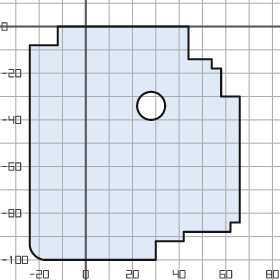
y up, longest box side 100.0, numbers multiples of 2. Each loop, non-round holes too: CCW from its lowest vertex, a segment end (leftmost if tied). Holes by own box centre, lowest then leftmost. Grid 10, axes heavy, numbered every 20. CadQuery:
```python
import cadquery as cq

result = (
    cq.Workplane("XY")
    .moveTo(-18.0, -100.0)
    .lineTo(30.0, -100.0)
    .lineTo(30.0, -92.0)
    .lineTo(42.0, -92.0)
    .lineTo(42.0, -88.0)
    .lineTo(62.0, -88.0)
    .lineTo(62.0, -84.0)
    .lineTo(66.0, -84.0)
    .lineTo(66.0, -30.0)
    .lineTo(58.0, -30.0)
    .lineTo(58.0, -18.0)
    .lineTo(54.0, -18.0)
    .lineTo(54.0, -14.0)
    .lineTo(44.0, -14.0)
    .lineTo(44.0, 0.0)
    .lineTo(-12.0, 0.0)
    .lineTo(-12.0, -8.0)
    .lineTo(-24.0, -8.0)
    .lineTo(-24.0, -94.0)
    .threePointArc((-22.0, -98.0), (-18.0, -100.0))
    .close()
    .moveTo(28.0, -34.0)
    .circle(6.0)
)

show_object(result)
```